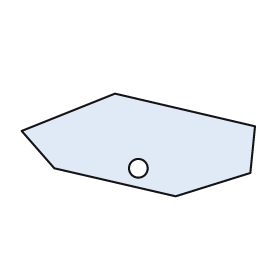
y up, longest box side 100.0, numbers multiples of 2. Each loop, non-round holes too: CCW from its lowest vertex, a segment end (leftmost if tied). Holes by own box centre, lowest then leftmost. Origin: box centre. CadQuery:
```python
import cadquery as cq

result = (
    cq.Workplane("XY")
    .moveTo(16.0, -22.0)
    .lineTo(48.0, -12.0)
    .lineTo(50.0, 8.0)
    .lineTo(-10.0, 22.0)
    .lineTo(-50.0, 6.0)
    .lineTo(-36.0, -10.0)
    .close()
    .moveTo(0.0, -10.0)
    .circle(4.0)
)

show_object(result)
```